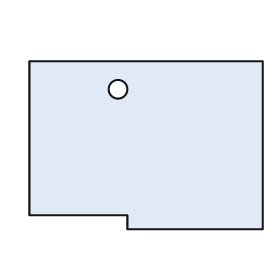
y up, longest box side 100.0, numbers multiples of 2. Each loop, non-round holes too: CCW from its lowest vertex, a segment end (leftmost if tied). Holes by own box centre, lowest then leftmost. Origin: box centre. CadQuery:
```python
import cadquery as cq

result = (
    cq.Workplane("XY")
    .moveTo(-8.0, -36.0)
    .lineTo(50.0, -36.0)
    .lineTo(50.0, 36.0)
    .lineTo(-50.0, 36.0)
    .lineTo(-50.0, -30.0)
    .lineTo(-8.0, -30.0)
    .close()
    .moveTo(-12.0, 24.0)
    .circle(4.0)
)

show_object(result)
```